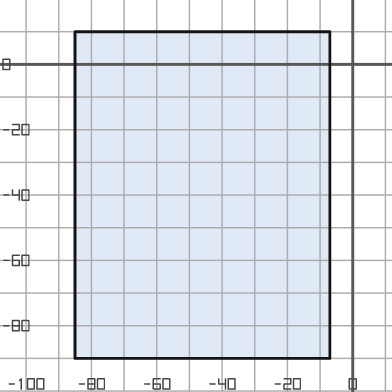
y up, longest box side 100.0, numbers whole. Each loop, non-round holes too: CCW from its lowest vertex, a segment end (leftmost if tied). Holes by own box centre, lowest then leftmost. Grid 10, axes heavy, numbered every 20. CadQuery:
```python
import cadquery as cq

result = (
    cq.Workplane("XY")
    .moveTo(-85.0, -90.0)
    .lineTo(-7.0, -90.0)
    .lineTo(-7.0, 10.0)
    .lineTo(-85.0, 10.0)
    .close()
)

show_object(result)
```